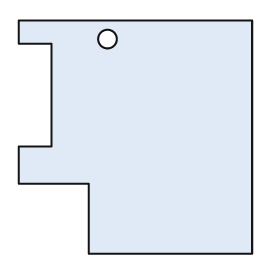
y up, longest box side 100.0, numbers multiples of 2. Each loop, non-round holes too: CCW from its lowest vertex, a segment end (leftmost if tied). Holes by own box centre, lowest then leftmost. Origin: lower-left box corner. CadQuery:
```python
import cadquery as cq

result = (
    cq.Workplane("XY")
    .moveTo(30.0, 0.0)
    .lineTo(100.0, 0.0)
    .lineTo(100.0, 100.0)
    .lineTo(0.0, 100.0)
    .lineTo(0.0, 90.0)
    .lineTo(14.0, 90.0)
    .lineTo(14.0, 46.0)
    .lineTo(0.0, 46.0)
    .lineTo(0.0, 30.0)
    .lineTo(30.0, 30.0)
    .close()
    .moveTo(38.0, 92.0)
    .circle(4.0)
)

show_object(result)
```